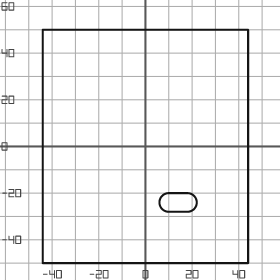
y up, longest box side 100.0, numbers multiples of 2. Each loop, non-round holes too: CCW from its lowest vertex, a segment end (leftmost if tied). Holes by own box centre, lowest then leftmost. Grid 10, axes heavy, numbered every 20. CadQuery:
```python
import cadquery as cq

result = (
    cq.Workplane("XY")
    .moveTo(-44.0, -50.0)
    .lineTo(44.0, -50.0)
    .lineTo(44.0, 50.0)
    .lineTo(-44.0, 50.0)
    .close()
    .moveTo(10.0, -28.0)
    .lineTo(18.0, -28.0)
    .threePointArc((22.0, -24.0), (18.0, -20.0))
    .lineTo(10.0, -20.0)
    .threePointArc((6.0, -24.0), (10.0, -28.0))
    .close()
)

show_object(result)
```